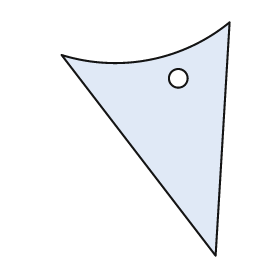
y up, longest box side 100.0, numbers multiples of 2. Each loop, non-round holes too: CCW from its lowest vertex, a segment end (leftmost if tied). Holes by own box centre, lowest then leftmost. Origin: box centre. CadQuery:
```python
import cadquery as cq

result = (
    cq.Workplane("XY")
    .moveTo(30.0, -50.0)
    .lineTo(36.0, 50.0)
    .threePointArc((2.0, 34.0), (-36.0, 36.0))
    .close()
    .moveTo(14.0, 26.0)
    .circle(4.0)
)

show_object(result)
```